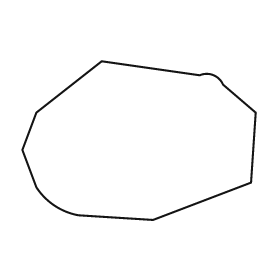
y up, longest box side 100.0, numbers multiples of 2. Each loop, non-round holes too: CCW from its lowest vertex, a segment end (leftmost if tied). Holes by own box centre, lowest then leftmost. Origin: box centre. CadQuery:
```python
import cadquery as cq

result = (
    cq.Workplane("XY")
    .moveTo(6.0, -34.0)
    .lineTo(48.0, -18.0)
    .lineTo(50.0, 12.0)
    .lineTo(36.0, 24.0)
    .threePointArc((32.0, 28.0), (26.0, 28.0))
    .lineTo(-16.0, 34.0)
    .lineTo(-44.0, 12.0)
    .lineTo(-50.0, -4.0)
    .lineTo(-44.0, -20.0)
    .threePointArc((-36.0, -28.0), (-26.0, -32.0))
    .close()
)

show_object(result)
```